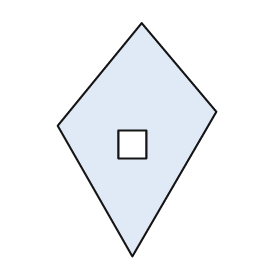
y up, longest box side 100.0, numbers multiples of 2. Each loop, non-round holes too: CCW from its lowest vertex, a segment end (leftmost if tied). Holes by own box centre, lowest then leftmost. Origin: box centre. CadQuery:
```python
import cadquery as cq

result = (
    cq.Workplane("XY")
    .moveTo(-2.0, -50.0)
    .lineTo(34.0, 12.0)
    .lineTo(2.0, 50.0)
    .lineTo(-34.0, 6.0)
    .close()
    .moveTo(-8.0, -8.0)
    .lineTo(4.0, -8.0)
    .lineTo(4.0, 4.0)
    .lineTo(-8.0, 4.0)
    .close()
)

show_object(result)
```